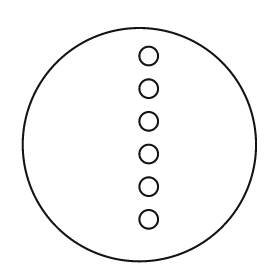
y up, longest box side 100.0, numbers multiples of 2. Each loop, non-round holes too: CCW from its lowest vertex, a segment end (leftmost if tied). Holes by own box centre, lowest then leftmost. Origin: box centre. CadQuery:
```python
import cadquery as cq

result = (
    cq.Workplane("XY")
    .moveTo(0.0, 0.0)
    .circle(50.0)
    .moveTo(4.0, -32.0)
    .circle(4.0)
    .moveTo(4.0, -18.0)
    .circle(4.0)
    .moveTo(4.0, -4.0)
    .circle(4.0)
    .moveTo(4.0, 10.0)
    .circle(4.0)
    .moveTo(4.0, 24.0)
    .circle(4.0)
    .moveTo(4.0, 38.0)
    .circle(4.0)
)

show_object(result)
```